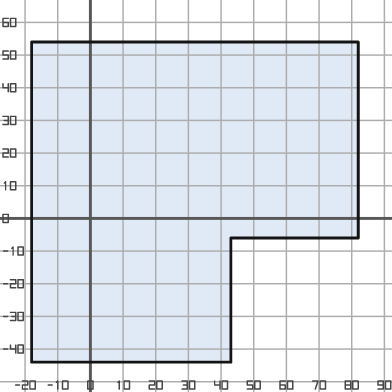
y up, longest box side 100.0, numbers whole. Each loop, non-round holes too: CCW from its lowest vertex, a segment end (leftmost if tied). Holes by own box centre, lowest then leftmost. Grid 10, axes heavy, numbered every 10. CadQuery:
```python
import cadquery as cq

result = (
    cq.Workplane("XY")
    .moveTo(-18.0, -44.0)
    .lineTo(43.0, -44.0)
    .lineTo(43.0, -6.0)
    .lineTo(82.0, -6.0)
    .lineTo(82.0, 54.0)
    .lineTo(-18.0, 54.0)
    .close()
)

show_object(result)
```